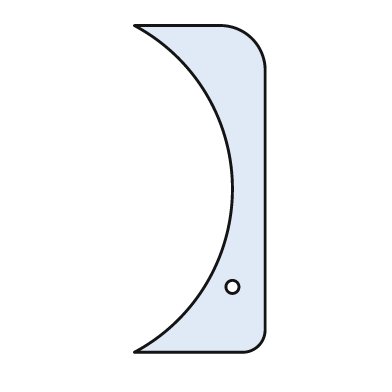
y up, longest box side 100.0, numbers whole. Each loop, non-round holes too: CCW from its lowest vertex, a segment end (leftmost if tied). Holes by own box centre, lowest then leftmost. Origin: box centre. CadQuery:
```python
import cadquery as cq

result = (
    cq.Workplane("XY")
    .moveTo(-20.0, -50.0)
    .lineTo(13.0, -50.0)
    .threePointArc((18.0, -48.0), (20.0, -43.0))
    .lineTo(20.0, 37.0)
    .threePointArc((16.0, 46.0), (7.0, 50.0))
    .lineTo(-20.0, 50.0)
    .threePointArc((10.0, 0.0), (-20.0, -50.0))
    .close()
    .moveTo(10.0, -30.0)
    .circle(2.0)
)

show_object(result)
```